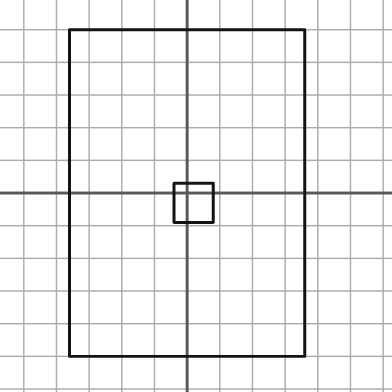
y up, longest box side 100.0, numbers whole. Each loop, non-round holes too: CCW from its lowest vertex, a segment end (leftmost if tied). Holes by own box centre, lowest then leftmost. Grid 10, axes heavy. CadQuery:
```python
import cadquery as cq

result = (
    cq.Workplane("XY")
    .moveTo(-36.0, -50.0)
    .lineTo(36.0, -50.0)
    .lineTo(36.0, 50.0)
    .lineTo(-36.0, 50.0)
    .close()
    .moveTo(-4.0, -9.0)
    .lineTo(8.0, -9.0)
    .lineTo(8.0, 3.0)
    .lineTo(-4.0, 3.0)
    .close()
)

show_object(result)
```